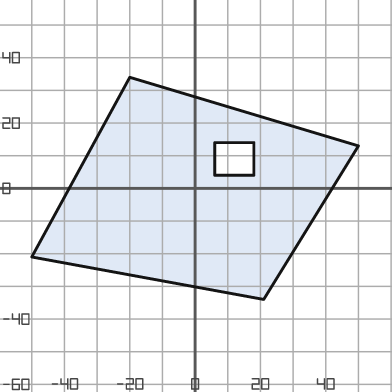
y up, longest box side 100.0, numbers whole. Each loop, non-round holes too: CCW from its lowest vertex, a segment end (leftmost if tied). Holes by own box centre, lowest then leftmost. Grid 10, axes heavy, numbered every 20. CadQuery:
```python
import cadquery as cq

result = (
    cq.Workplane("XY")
    .moveTo(21.0, -34.0)
    .lineTo(50.0, 13.0)
    .lineTo(-20.0, 34.0)
    .lineTo(-50.0, -21.0)
    .close()
    .moveTo(6.0, 4.0)
    .lineTo(18.0, 4.0)
    .lineTo(18.0, 14.0)
    .lineTo(6.0, 14.0)
    .close()
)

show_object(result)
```